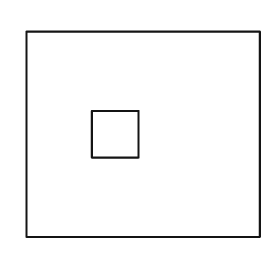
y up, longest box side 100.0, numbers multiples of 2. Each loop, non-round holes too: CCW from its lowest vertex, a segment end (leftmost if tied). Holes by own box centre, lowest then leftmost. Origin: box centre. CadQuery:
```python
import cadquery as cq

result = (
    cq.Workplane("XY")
    .moveTo(-50.0, -44.0)
    .lineTo(50.0, -44.0)
    .lineTo(50.0, 44.0)
    .lineTo(-50.0, 44.0)
    .close()
    .moveTo(-22.0, -10.0)
    .lineTo(-2.0, -10.0)
    .lineTo(-2.0, 10.0)
    .lineTo(-22.0, 10.0)
    .close()
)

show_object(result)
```